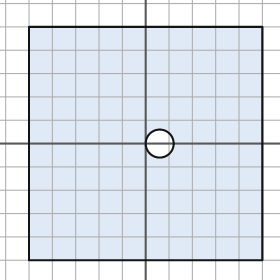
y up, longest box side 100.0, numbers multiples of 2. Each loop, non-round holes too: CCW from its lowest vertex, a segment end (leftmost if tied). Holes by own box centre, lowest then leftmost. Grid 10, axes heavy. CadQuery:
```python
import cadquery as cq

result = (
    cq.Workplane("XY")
    .moveTo(-50.0, -50.0)
    .lineTo(50.0, -50.0)
    .lineTo(50.0, 50.0)
    .lineTo(-50.0, 50.0)
    .close()
    .moveTo(6.0, 0.0)
    .circle(6.0)
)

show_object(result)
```